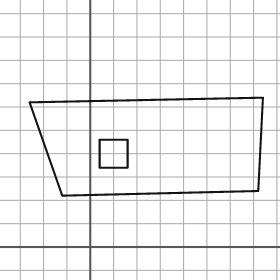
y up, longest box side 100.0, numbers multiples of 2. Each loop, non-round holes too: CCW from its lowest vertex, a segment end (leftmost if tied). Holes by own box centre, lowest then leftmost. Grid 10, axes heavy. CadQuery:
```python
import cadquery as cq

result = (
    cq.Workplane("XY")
    .moveTo(-12.0, 22.0)
    .lineTo(72.0, 24.0)
    .lineTo(74.0, 64.0)
    .lineTo(-26.0, 62.0)
    .close()
    .moveTo(4.0, 34.0)
    .lineTo(16.0, 34.0)
    .lineTo(16.0, 46.0)
    .lineTo(4.0, 46.0)
    .close()
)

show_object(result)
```